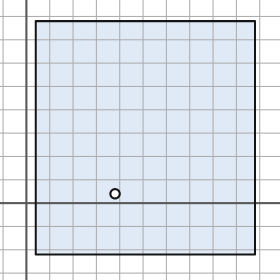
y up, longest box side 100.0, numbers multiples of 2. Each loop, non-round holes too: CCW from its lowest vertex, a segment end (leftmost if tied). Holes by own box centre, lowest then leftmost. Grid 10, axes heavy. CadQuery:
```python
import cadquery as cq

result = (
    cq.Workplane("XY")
    .moveTo(4.0, -22.0)
    .lineTo(98.0, -22.0)
    .lineTo(98.0, 78.0)
    .lineTo(4.0, 78.0)
    .close()
    .moveTo(38.0, 4.0)
    .circle(2.0)
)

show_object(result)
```